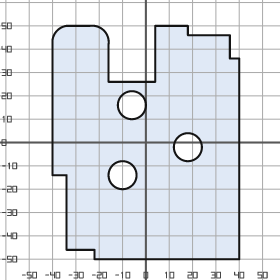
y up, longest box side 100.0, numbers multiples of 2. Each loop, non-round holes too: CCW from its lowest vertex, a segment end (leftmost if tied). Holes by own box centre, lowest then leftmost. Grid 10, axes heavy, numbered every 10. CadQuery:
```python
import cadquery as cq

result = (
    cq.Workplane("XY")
    .moveTo(-22.0, -50.0)
    .lineTo(40.0, -50.0)
    .lineTo(40.0, 36.0)
    .lineTo(36.0, 36.0)
    .lineTo(36.0, 46.0)
    .lineTo(18.0, 46.0)
    .lineTo(18.0, 50.0)
    .lineTo(4.0, 50.0)
    .lineTo(4.0, 26.0)
    .lineTo(-16.0, 26.0)
    .lineTo(-16.0, 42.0)
    .threePointArc((-18.0, 48.0), (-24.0, 50.0))
    .lineTo(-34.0, 50.0)
    .threePointArc((-38.0, 48.0), (-40.0, 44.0))
    .lineTo(-40.0, -14.0)
    .lineTo(-34.0, -14.0)
    .lineTo(-34.0, -46.0)
    .lineTo(-22.0, -46.0)
    .close()
    .moveTo(-10.0, -14.0)
    .circle(6.0)
    .moveTo(18.0, -2.0)
    .circle(6.0)
    .moveTo(-6.0, 16.0)
    .circle(6.0)
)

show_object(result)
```